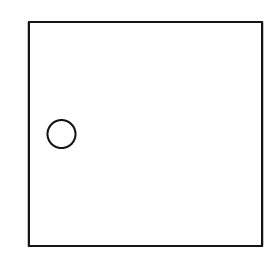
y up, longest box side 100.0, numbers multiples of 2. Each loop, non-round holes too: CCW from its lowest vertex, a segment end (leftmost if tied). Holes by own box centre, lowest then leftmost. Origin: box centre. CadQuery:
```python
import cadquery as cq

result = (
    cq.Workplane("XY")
    .moveTo(-50.0, -48.0)
    .lineTo(50.0, -48.0)
    .lineTo(50.0, 48.0)
    .lineTo(-50.0, 48.0)
    .close()
    .moveTo(-36.0, 0.0)
    .circle(6.0)
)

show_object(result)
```